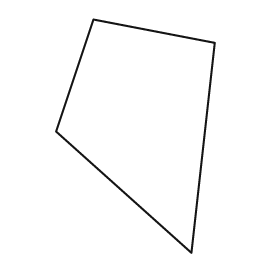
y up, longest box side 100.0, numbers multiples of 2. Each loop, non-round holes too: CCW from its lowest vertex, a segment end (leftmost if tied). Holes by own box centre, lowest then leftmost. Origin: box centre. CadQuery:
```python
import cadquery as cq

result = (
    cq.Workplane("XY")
    .moveTo(24.0, -50.0)
    .lineTo(34.0, 40.0)
    .lineTo(-18.0, 50.0)
    .lineTo(-34.0, 2.0)
    .close()
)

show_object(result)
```